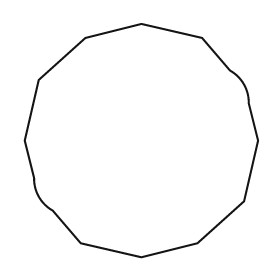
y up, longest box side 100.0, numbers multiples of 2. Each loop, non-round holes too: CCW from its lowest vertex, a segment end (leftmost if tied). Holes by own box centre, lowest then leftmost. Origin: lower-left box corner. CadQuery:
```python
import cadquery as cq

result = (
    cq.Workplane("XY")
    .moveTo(50.0, 0.0)
    .lineTo(74.0, 6.0)
    .lineTo(94.0, 24.0)
    .lineTo(100.0, 50.0)
    .lineTo(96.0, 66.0)
    .threePointArc((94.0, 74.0), (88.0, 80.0))
    .lineTo(76.0, 94.0)
    .lineTo(50.0, 100.0)
    .lineTo(26.0, 94.0)
    .lineTo(6.0, 76.0)
    .lineTo(0.0, 50.0)
    .lineTo(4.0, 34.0)
    .threePointArc((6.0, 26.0), (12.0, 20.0))
    .lineTo(24.0, 6.0)
    .close()
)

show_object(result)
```